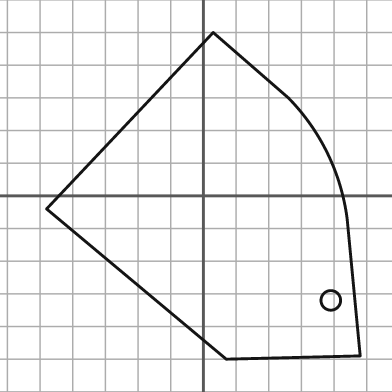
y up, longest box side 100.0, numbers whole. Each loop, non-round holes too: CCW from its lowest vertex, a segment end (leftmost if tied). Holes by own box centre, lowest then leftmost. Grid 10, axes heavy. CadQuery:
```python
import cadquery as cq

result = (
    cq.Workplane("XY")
    .moveTo(7.0, -50.0)
    .lineTo(48.0, -49.0)
    .lineTo(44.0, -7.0)
    .threePointArc((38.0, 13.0), (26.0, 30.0))
    .lineTo(3.0, 50.0)
    .lineTo(-48.0, -4.0)
    .close()
    .moveTo(39.0, -32.0)
    .circle(3.0)
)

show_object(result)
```